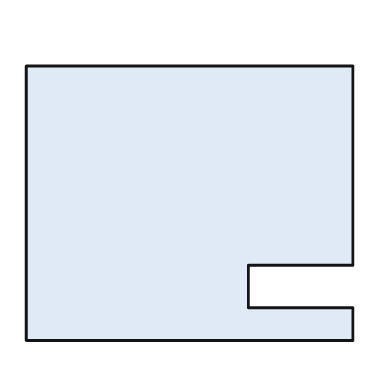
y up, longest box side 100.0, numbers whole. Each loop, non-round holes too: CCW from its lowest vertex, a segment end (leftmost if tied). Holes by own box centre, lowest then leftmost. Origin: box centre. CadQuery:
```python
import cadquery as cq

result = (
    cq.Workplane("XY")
    .moveTo(-50.0, -42.0)
    .lineTo(50.0, -42.0)
    .lineTo(50.0, -32.0)
    .lineTo(18.0, -32.0)
    .lineTo(18.0, -19.0)
    .lineTo(50.0, -19.0)
    .lineTo(50.0, 42.0)
    .lineTo(-50.0, 42.0)
    .close()
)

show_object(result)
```